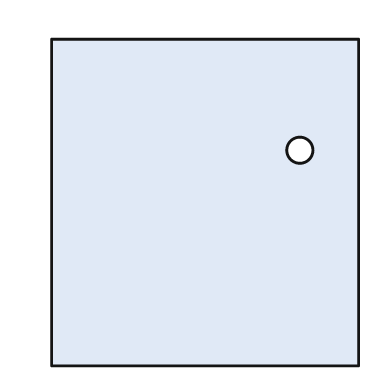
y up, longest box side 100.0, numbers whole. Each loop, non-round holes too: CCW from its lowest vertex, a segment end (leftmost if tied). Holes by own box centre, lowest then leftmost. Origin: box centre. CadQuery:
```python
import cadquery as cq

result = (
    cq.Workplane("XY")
    .moveTo(-47.0, -50.0)
    .lineTo(47.0, -50.0)
    .lineTo(47.0, 50.0)
    .lineTo(-47.0, 50.0)
    .close()
    .moveTo(29.0, 16.0)
    .circle(4.0)
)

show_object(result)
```